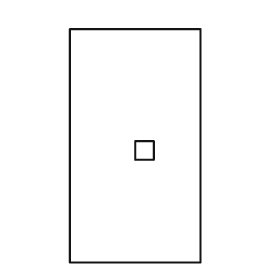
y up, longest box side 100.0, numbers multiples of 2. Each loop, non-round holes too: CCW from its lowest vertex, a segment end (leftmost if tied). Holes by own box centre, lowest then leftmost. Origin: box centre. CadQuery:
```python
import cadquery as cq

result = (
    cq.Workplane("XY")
    .moveTo(-28.0, -50.0)
    .lineTo(28.0, -50.0)
    .lineTo(28.0, 50.0)
    .lineTo(-28.0, 50.0)
    .close()
    .moveTo(0.0, -6.0)
    .lineTo(8.0, -6.0)
    .lineTo(8.0, 2.0)
    .lineTo(0.0, 2.0)
    .close()
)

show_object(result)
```